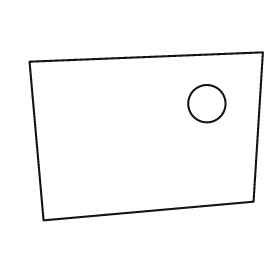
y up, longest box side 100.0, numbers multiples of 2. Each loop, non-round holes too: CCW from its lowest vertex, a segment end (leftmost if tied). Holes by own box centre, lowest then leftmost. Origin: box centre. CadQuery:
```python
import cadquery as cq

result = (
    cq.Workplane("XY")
    .moveTo(-44.0, -36.0)
    .lineTo(46.0, -28.0)
    .lineTo(50.0, 36.0)
    .lineTo(-50.0, 32.0)
    .close()
    .moveTo(26.0, 14.0)
    .circle(8.0)
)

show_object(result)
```